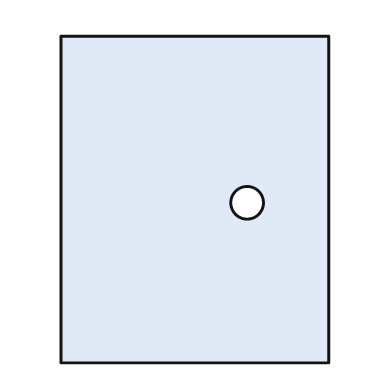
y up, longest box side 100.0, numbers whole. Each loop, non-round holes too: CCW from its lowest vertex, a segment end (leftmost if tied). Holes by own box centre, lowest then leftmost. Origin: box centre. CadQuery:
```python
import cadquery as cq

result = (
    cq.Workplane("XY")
    .moveTo(-41.0, -50.0)
    .lineTo(41.0, -50.0)
    .lineTo(41.0, 50.0)
    .lineTo(-41.0, 50.0)
    .close()
    .moveTo(16.0, -1.0)
    .circle(5.0)
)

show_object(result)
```